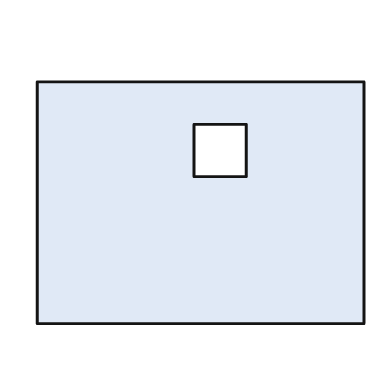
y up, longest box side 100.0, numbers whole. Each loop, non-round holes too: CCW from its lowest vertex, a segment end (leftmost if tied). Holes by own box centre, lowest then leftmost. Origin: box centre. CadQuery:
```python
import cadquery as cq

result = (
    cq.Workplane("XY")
    .moveTo(-50.0, -37.0)
    .lineTo(50.0, -37.0)
    .lineTo(50.0, 37.0)
    .lineTo(-50.0, 37.0)
    .close()
    .moveTo(-2.0, 8.0)
    .lineTo(14.0, 8.0)
    .lineTo(14.0, 24.0)
    .lineTo(-2.0, 24.0)
    .close()
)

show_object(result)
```